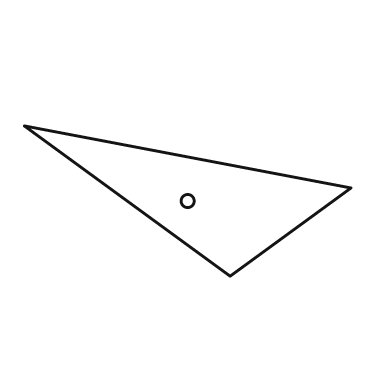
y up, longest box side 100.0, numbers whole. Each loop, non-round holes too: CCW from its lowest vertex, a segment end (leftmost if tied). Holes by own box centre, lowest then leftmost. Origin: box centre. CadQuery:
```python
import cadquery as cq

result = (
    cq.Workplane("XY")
    .moveTo(13.0, -23.0)
    .lineTo(50.0, 4.0)
    .lineTo(-50.0, 23.0)
    .close()
    .moveTo(0.0, 0.0)
    .circle(2.0)
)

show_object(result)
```